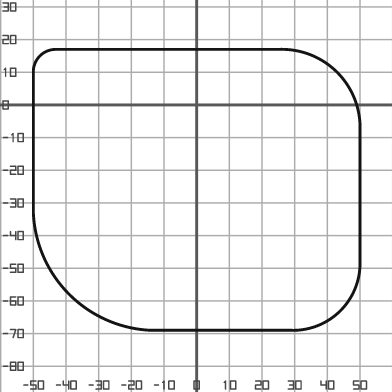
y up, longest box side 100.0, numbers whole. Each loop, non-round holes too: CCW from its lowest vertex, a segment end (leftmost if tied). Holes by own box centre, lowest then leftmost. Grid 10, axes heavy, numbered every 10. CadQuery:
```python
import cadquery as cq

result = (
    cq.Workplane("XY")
    .moveTo(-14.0, -69.0)
    .lineTo(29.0, -69.0)
    .threePointArc((44.0, -63.0), (50.0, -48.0))
    .lineTo(50.0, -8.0)
    .threePointArc((43.0, 10.0), (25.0, 17.0))
    .lineTo(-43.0, 17.0)
    .threePointArc((-48.0, 15.0), (-50.0, 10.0))
    .lineTo(-50.0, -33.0)
    .threePointArc((-39.0, -58.0), (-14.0, -69.0))
    .close()
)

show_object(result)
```